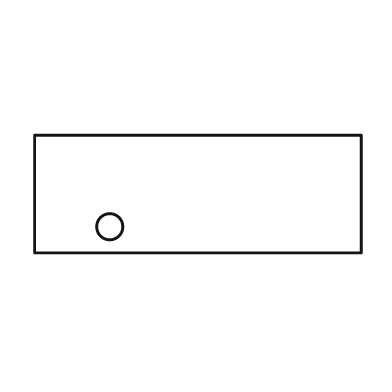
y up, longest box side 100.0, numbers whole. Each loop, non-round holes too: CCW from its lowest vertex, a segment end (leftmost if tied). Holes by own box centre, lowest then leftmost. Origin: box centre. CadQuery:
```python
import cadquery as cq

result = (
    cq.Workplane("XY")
    .moveTo(-50.0, -18.0)
    .lineTo(50.0, -18.0)
    .lineTo(50.0, 18.0)
    .lineTo(-50.0, 18.0)
    .close()
    .moveTo(-27.0, -10.0)
    .circle(4.0)
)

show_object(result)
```